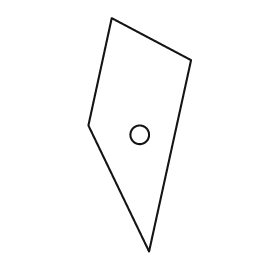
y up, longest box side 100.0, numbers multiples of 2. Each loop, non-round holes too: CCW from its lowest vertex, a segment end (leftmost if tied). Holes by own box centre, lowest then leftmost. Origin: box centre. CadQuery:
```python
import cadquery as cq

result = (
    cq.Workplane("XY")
    .moveTo(4.0, -50.0)
    .lineTo(22.0, 32.0)
    .lineTo(-12.0, 50.0)
    .lineTo(-22.0, 4.0)
    .close()
    .moveTo(0.0, 0.0)
    .circle(4.0)
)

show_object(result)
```